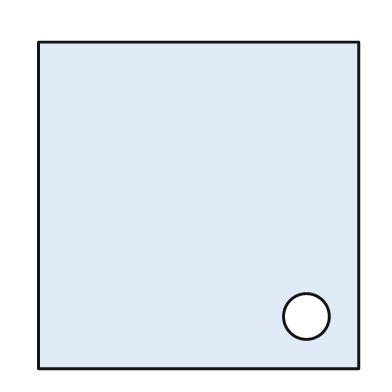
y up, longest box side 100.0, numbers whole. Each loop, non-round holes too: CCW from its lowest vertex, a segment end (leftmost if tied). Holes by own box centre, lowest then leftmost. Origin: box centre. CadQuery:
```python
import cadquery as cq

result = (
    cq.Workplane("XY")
    .moveTo(-49.0, -50.0)
    .lineTo(49.0, -50.0)
    .lineTo(49.0, 50.0)
    .lineTo(-49.0, 50.0)
    .close()
    .moveTo(33.0, -34.0)
    .circle(7.0)
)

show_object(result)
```